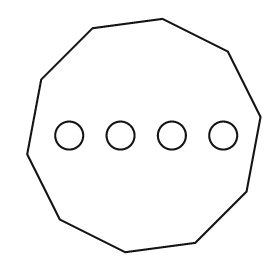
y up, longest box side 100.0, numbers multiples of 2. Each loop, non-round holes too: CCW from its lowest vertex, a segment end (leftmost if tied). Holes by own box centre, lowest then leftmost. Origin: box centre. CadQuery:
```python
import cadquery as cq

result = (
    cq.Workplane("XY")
    .moveTo(-8.0, -50.0)
    .lineTo(22.0, -46.0)
    .lineTo(44.0, -24.0)
    .lineTo(50.0, 8.0)
    .lineTo(36.0, 36.0)
    .lineTo(8.0, 50.0)
    .lineTo(-22.0, 46.0)
    .lineTo(-44.0, 24.0)
    .lineTo(-50.0, -8.0)
    .lineTo(-36.0, -36.0)
    .close()
    .moveTo(-32.0, 0.0)
    .circle(6.0)
    .moveTo(-10.0, 0.0)
    .circle(6.0)
    .moveTo(12.0, 0.0)
    .circle(6.0)
    .moveTo(34.0, 0.0)
    .circle(6.0)
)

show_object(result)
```